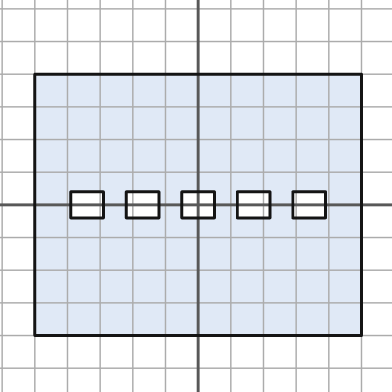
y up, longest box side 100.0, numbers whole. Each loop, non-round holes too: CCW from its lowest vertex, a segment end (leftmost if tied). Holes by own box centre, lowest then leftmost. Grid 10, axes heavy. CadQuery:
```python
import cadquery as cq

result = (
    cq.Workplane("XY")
    .moveTo(-50.0, -40.0)
    .lineTo(50.0, -40.0)
    .lineTo(50.0, 40.0)
    .lineTo(-50.0, 40.0)
    .close()
    .moveTo(-39.0, -4.0)
    .lineTo(-29.0, -4.0)
    .lineTo(-29.0, 4.0)
    .lineTo(-39.0, 4.0)
    .close()
    .moveTo(-22.0, -4.0)
    .lineTo(-12.0, -4.0)
    .lineTo(-12.0, 4.0)
    .lineTo(-22.0, 4.0)
    .close()
    .moveTo(-5.0, -4.0)
    .lineTo(5.0, -4.0)
    .lineTo(5.0, 4.0)
    .lineTo(-5.0, 4.0)
    .close()
    .moveTo(12.0, -4.0)
    .lineTo(22.0, -4.0)
    .lineTo(22.0, 4.0)
    .lineTo(12.0, 4.0)
    .close()
    .moveTo(29.0, -4.0)
    .lineTo(39.0, -4.0)
    .lineTo(39.0, 4.0)
    .lineTo(29.0, 4.0)
    .close()
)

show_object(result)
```